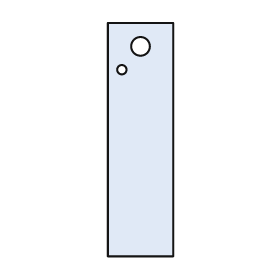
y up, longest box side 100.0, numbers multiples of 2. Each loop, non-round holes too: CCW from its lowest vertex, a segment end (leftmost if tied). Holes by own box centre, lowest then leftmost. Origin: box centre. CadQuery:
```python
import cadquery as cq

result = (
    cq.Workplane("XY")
    .moveTo(-14.0, -50.0)
    .lineTo(14.0, -50.0)
    .lineTo(14.0, 50.0)
    .lineTo(-14.0, 50.0)
    .close()
    .moveTo(-8.0, 30.0)
    .circle(2.0)
    .moveTo(0.0, 40.0)
    .circle(4.0)
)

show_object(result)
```